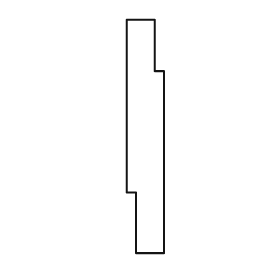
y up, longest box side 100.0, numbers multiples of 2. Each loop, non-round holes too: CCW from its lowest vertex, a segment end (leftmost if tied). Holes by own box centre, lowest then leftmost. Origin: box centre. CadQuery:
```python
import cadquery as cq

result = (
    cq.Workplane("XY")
    .moveTo(-4.0, -50.0)
    .lineTo(8.0, -50.0)
    .lineTo(8.0, 28.0)
    .lineTo(4.0, 28.0)
    .lineTo(4.0, 50.0)
    .lineTo(-8.0, 50.0)
    .lineTo(-8.0, -24.0)
    .lineTo(-4.0, -24.0)
    .close()
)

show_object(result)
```